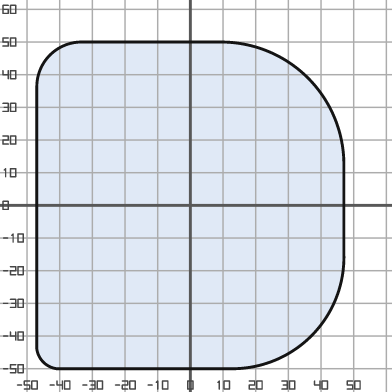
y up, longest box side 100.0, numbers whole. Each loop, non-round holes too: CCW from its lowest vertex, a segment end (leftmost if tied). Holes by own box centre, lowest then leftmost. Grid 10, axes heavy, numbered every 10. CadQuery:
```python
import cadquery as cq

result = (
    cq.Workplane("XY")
    .moveTo(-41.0, -50.0)
    .lineTo(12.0, -50.0)
    .threePointArc((37.0, -40.0), (47.0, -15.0))
    .lineTo(47.0, 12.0)
    .threePointArc((36.0, 39.0), (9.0, 50.0))
    .lineTo(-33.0, 50.0)
    .threePointArc((-43.0, 46.0), (-47.0, 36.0))
    .lineTo(-47.0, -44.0)
    .threePointArc((-45.0, -48.0), (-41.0, -50.0))
    .close()
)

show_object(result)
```